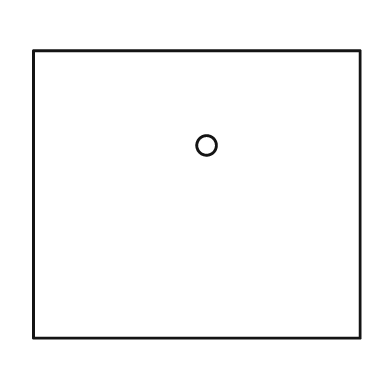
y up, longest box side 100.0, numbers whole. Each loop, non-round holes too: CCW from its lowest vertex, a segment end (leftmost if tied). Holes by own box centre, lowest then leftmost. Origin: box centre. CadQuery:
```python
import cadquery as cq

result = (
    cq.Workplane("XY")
    .moveTo(-50.0, -44.0)
    .lineTo(50.0, -44.0)
    .lineTo(50.0, 44.0)
    .lineTo(-50.0, 44.0)
    .close()
    .moveTo(3.0, 15.0)
    .circle(3.0)
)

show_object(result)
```